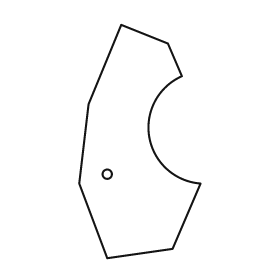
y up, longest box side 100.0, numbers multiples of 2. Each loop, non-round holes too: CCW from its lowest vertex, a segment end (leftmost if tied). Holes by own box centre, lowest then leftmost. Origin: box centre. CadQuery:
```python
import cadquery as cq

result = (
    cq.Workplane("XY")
    .moveTo(-14.0, -50.0)
    .lineTo(14.0, -46.0)
    .lineTo(26.0, -18.0)
    .threePointArc((4.0, 2.0), (18.0, 28.0))
    .lineTo(12.0, 42.0)
    .lineTo(-8.0, 50.0)
    .lineTo(-22.0, 16.0)
    .lineTo(-26.0, -18.0)
    .close()
    .moveTo(-14.0, -14.0)
    .circle(2.0)
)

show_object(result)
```